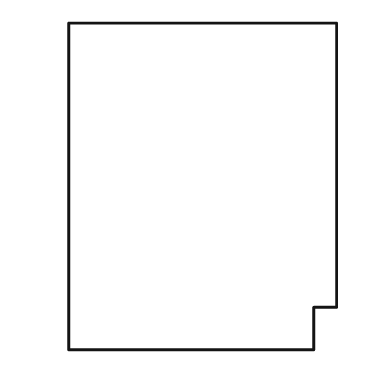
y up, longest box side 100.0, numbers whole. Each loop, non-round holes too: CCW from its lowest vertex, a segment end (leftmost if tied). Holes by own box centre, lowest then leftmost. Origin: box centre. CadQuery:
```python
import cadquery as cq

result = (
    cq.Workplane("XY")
    .moveTo(-41.0, -50.0)
    .lineTo(34.0, -50.0)
    .lineTo(34.0, -37.0)
    .lineTo(41.0, -37.0)
    .lineTo(41.0, 50.0)
    .lineTo(-41.0, 50.0)
    .close()
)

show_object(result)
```